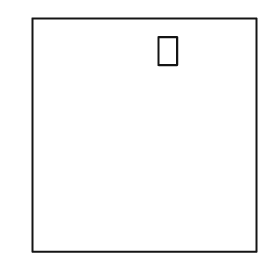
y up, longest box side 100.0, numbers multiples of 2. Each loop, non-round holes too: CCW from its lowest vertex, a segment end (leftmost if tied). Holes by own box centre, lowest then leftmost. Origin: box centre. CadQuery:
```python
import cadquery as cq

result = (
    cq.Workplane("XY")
    .moveTo(-48.0, -50.0)
    .lineTo(48.0, -50.0)
    .lineTo(48.0, 50.0)
    .lineTo(-48.0, 50.0)
    .close()
    .moveTo(6.0, 30.0)
    .lineTo(14.0, 30.0)
    .lineTo(14.0, 42.0)
    .lineTo(6.0, 42.0)
    .close()
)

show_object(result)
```